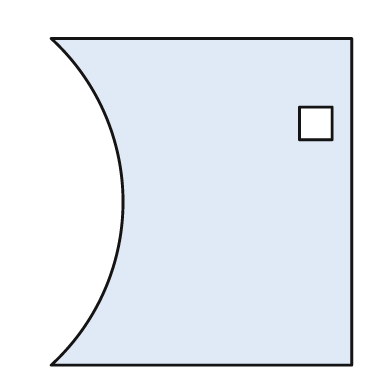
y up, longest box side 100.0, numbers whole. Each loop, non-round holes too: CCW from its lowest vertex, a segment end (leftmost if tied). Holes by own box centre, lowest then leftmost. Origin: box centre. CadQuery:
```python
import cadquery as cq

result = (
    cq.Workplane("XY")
    .moveTo(-46.0, -50.0)
    .lineTo(46.0, -50.0)
    .lineTo(46.0, 50.0)
    .lineTo(-46.0, 50.0)
    .threePointArc((-24.0, 0.0), (-46.0, -50.0))
    .close()
    .moveTo(30.0, 19.0)
    .lineTo(40.0, 19.0)
    .lineTo(40.0, 29.0)
    .lineTo(30.0, 29.0)
    .close()
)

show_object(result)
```